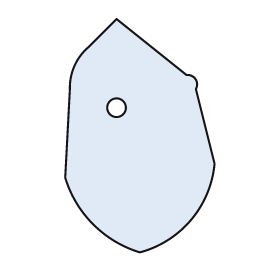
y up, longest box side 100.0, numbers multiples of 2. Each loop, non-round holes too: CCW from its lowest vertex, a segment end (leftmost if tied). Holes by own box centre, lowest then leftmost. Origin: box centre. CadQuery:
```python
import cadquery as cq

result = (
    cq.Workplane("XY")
    .moveTo(0.0, -50.0)
    .threePointArc((22.0, -36.0), (32.0, -12.0))
    .lineTo(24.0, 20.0)
    .threePointArc((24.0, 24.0), (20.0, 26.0))
    .lineTo(-10.0, 50.0)
    .lineTo(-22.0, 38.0)
    .threePointArc((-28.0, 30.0), (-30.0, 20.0))
    .lineTo(-32.0, -18.0)
    .threePointArc((-20.0, -38.0), (0.0, -50.0))
    .close()
    .moveTo(-10.0, 12.0)
    .circle(4.0)
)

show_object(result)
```